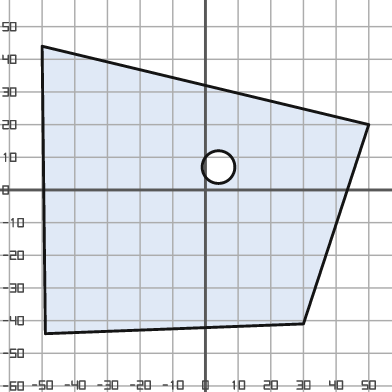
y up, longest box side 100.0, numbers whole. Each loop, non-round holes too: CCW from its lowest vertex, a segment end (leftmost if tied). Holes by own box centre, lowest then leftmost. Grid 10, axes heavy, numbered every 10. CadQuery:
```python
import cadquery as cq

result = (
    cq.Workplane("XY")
    .moveTo(-49.0, -44.0)
    .lineTo(30.0, -41.0)
    .lineTo(50.0, 20.0)
    .lineTo(-50.0, 44.0)
    .close()
    .moveTo(4.0, 7.0)
    .circle(5.0)
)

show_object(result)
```